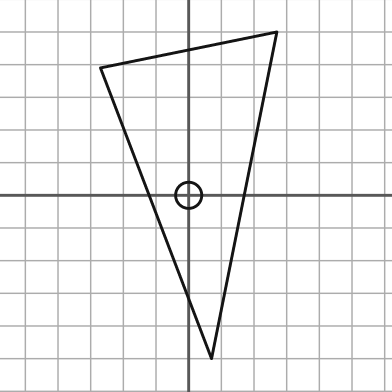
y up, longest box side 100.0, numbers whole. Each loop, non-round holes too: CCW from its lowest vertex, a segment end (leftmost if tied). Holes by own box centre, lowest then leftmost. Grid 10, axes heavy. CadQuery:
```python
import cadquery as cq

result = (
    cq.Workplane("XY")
    .moveTo(7.0, -50.0)
    .lineTo(27.0, 50.0)
    .lineTo(-27.0, 39.0)
    .close()
    .moveTo(0.0, 0.0)
    .circle(4.0)
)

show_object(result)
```